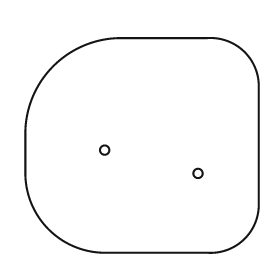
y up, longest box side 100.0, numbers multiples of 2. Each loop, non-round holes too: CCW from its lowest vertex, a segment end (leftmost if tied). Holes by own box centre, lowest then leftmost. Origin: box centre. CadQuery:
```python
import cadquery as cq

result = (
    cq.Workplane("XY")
    .moveTo(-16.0, -46.0)
    .lineTo(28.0, -46.0)
    .threePointArc((44.0, -40.0), (50.0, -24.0))
    .lineTo(50.0, 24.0)
    .threePointArc((44.0, 40.0), (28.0, 46.0))
    .lineTo(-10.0, 46.0)
    .threePointArc((-38.0, 34.0), (-50.0, 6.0))
    .lineTo(-50.0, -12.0)
    .threePointArc((-40.0, -36.0), (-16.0, -46.0))
    .close()
    .moveTo(24.0, -12.0)
    .circle(2.0)
    .moveTo(-16.0, -2.0)
    .circle(2.0)
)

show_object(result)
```